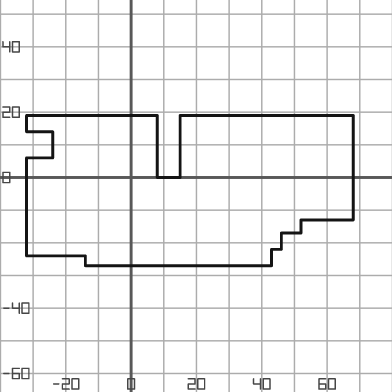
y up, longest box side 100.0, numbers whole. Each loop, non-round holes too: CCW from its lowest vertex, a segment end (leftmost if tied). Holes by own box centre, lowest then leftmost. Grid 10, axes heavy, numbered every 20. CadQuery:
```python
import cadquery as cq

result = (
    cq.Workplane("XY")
    .moveTo(-14.0, -27.0)
    .lineTo(43.0, -27.0)
    .lineTo(43.0, -22.0)
    .lineTo(46.0, -22.0)
    .lineTo(46.0, -17.0)
    .lineTo(52.0, -17.0)
    .lineTo(52.0, -13.0)
    .lineTo(68.0, -13.0)
    .lineTo(68.0, 19.0)
    .lineTo(15.0, 19.0)
    .lineTo(15.0, 0.0)
    .lineTo(8.0, 0.0)
    .lineTo(8.0, 19.0)
    .lineTo(-32.0, 19.0)
    .lineTo(-32.0, 14.0)
    .lineTo(-24.0, 14.0)
    .lineTo(-24.0, 6.0)
    .lineTo(-32.0, 6.0)
    .lineTo(-32.0, -24.0)
    .lineTo(-14.0, -24.0)
    .close()
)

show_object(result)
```